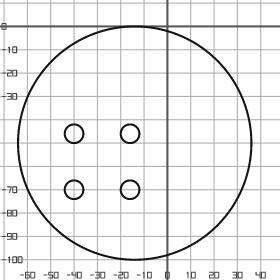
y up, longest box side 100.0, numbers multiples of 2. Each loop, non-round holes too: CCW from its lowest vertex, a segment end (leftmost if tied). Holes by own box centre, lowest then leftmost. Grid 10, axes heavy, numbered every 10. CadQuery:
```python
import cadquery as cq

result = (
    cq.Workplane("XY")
    .moveTo(-14.0, -50.0)
    .circle(50.0)
    .moveTo(-40.0, -70.0)
    .circle(4.0)
    .moveTo(-16.0, -70.0)
    .circle(4.0)
    .moveTo(-40.0, -46.0)
    .circle(4.0)
    .moveTo(-16.0, -46.0)
    .circle(4.0)
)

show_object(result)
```